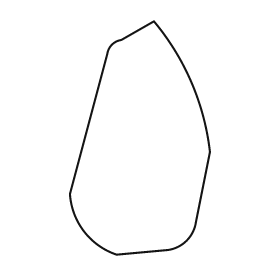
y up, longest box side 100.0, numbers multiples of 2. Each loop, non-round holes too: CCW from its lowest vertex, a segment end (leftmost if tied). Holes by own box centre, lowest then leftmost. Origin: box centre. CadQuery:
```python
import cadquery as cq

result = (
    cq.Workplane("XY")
    .moveTo(-10.0, -50.0)
    .lineTo(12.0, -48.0)
    .threePointArc((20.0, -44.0), (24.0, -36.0))
    .lineTo(30.0, -6.0)
    .threePointArc((22.0, 24.0), (6.0, 50.0))
    .lineTo(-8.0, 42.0)
    .threePointArc((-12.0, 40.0), (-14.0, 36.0))
    .lineTo(-30.0, -24.0)
    .threePointArc((-24.0, -40.0), (-10.0, -50.0))
    .close()
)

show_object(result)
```